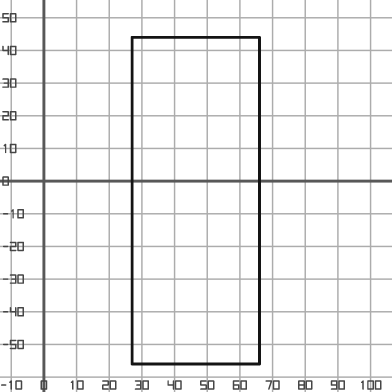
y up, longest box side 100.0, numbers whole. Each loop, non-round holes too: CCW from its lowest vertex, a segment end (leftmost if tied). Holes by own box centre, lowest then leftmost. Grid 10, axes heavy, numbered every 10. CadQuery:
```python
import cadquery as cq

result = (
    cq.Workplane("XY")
    .moveTo(27.0, -56.0)
    .lineTo(66.0, -56.0)
    .lineTo(66.0, 44.0)
    .lineTo(27.0, 44.0)
    .close()
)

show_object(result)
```